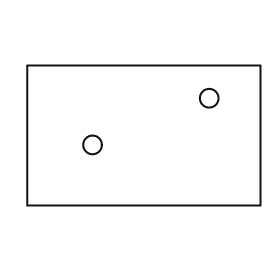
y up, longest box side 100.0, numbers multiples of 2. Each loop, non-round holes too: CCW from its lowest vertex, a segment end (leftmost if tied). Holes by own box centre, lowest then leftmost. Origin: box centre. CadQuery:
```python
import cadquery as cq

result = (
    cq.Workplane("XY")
    .moveTo(-50.0, -30.0)
    .lineTo(50.0, -30.0)
    .lineTo(50.0, 30.0)
    .lineTo(-50.0, 30.0)
    .close()
    .moveTo(-22.0, -4.0)
    .circle(4.0)
    .moveTo(28.0, 16.0)
    .circle(4.0)
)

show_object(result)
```